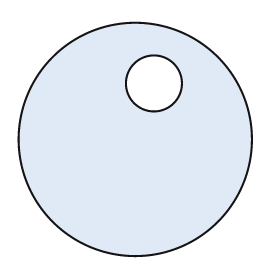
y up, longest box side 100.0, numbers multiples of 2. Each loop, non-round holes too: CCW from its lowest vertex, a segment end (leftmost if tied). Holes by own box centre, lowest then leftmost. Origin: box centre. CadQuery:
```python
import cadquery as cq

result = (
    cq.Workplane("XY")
    .moveTo(0.0, 0.0)
    .circle(50.0)
    .moveTo(8.0, 24.0)
    .circle(12.0)
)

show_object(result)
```